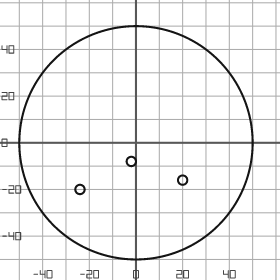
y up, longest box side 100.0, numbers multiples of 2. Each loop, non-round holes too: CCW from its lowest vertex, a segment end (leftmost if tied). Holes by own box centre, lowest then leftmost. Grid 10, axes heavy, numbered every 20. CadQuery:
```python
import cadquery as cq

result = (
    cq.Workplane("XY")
    .moveTo(0.0, 0.0)
    .circle(50.0)
    .moveTo(-24.0, -20.0)
    .circle(2.0)
    .moveTo(20.0, -16.0)
    .circle(2.0)
    .moveTo(-2.0, -8.0)
    .circle(2.0)
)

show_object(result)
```